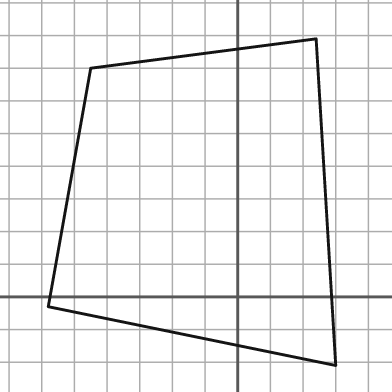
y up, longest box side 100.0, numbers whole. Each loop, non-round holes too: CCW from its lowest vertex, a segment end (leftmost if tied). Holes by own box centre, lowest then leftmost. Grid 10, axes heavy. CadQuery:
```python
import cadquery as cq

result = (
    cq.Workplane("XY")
    .moveTo(30.0, -21.0)
    .lineTo(24.0, 79.0)
    .lineTo(-45.0, 70.0)
    .lineTo(-58.0, -3.0)
    .close()
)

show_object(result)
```